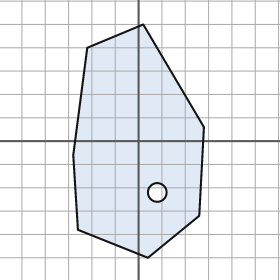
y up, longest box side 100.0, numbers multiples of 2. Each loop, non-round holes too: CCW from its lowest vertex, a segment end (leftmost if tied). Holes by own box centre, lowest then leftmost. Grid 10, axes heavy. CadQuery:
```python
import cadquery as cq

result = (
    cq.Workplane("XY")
    .moveTo(4.0, -50.0)
    .lineTo(26.0, -32.0)
    .lineTo(28.0, 6.0)
    .lineTo(2.0, 50.0)
    .lineTo(-22.0, 40.0)
    .lineTo(-28.0, -6.0)
    .lineTo(-26.0, -38.0)
    .close()
    .moveTo(8.0, -22.0)
    .circle(4.0)
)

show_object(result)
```